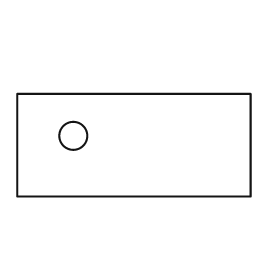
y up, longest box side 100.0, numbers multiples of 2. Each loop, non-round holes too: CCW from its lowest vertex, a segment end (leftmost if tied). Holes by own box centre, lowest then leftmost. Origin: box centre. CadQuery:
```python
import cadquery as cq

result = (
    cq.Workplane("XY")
    .moveTo(-50.0, -22.0)
    .lineTo(50.0, -22.0)
    .lineTo(50.0, 22.0)
    .lineTo(-50.0, 22.0)
    .close()
    .moveTo(-26.0, 4.0)
    .circle(6.0)
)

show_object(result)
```